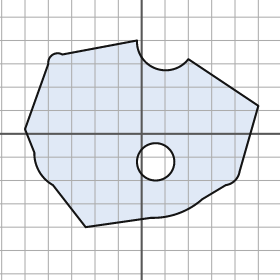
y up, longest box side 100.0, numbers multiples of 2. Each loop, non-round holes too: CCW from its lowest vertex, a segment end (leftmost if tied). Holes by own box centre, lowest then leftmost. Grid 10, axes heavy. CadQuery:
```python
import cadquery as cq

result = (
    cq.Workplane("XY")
    .moveTo(-24.0, -40.0)
    .lineTo(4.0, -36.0)
    .threePointArc((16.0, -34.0), (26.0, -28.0))
    .lineTo(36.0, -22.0)
    .threePointArc((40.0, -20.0), (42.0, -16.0))
    .lineTo(50.0, 12.0)
    .lineTo(20.0, 32.0)
    .threePointArc((6.0, 28.0), (-2.0, 40.0))
    .lineTo(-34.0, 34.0)
    .threePointArc((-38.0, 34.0), (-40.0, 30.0))
    .lineTo(-50.0, 2.0)
    .lineTo(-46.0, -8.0)
    .threePointArc((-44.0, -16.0), (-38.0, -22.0))
    .close()
    .moveTo(6.0, -12.0)
    .circle(8.0)
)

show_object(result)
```